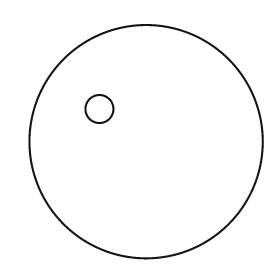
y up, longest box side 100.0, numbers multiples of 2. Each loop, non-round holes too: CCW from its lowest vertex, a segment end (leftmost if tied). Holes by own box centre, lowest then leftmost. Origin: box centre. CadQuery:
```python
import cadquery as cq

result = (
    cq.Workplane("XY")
    .moveTo(0.0, 0.0)
    .circle(50.0)
    .moveTo(-20.0, 14.0)
    .circle(6.0)
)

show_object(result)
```